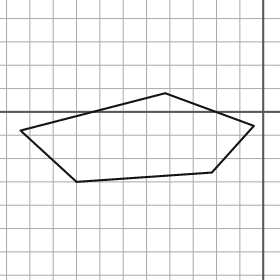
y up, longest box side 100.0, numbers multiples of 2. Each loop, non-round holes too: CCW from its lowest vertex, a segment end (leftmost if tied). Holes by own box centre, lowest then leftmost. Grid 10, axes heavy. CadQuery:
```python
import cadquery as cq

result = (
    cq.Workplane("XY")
    .moveTo(-80.0, -30.0)
    .lineTo(-22.0, -26.0)
    .lineTo(-4.0, -6.0)
    .lineTo(-42.0, 8.0)
    .lineTo(-104.0, -8.0)
    .close()
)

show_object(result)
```